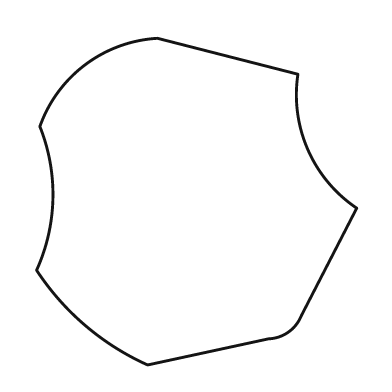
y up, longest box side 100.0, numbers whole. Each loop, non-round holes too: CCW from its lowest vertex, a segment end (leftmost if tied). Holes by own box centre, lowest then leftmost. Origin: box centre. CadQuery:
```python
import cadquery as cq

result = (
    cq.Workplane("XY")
    .moveTo(-15.0, -50.0)
    .lineTo(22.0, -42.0)
    .threePointArc((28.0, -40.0), (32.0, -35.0))
    .lineTo(49.0, -2.0)
    .threePointArc((34.0, 16.0), (31.0, 39.0))
    .lineTo(-12.0, 50.0)
    .threePointArc((-34.0, 42.0), (-48.0, 23.0))
    .threePointArc((-44.0, 1.0), (-49.0, -21.0))
    .threePointArc((-34.0, -38.0), (-15.0, -50.0))
    .close()
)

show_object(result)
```